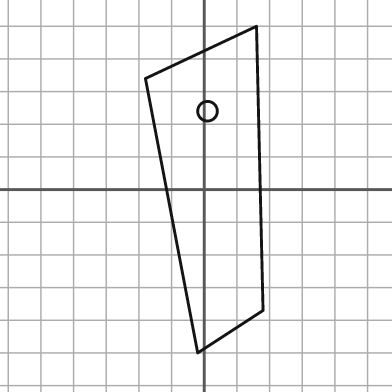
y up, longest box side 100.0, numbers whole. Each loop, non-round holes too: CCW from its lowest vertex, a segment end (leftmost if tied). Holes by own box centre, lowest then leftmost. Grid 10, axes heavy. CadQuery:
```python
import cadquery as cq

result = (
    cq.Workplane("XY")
    .moveTo(-2.0, -50.0)
    .lineTo(18.0, -37.0)
    .lineTo(16.0, 50.0)
    .lineTo(-18.0, 34.0)
    .close()
    .moveTo(1.0, 24.0)
    .circle(3.0)
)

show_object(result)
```